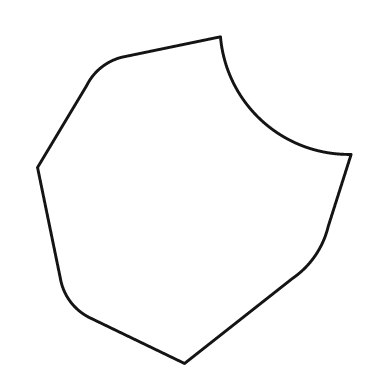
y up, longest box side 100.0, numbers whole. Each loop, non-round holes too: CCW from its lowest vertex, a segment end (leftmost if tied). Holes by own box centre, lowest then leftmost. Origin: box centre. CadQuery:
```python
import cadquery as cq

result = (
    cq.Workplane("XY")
    .moveTo(-3.0, -50.0)
    .lineTo(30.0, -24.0)
    .threePointArc((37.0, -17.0), (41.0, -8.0))
    .lineTo(48.0, 14.0)
    .threePointArc((21.0, 24.0), (8.0, 50.0))
    .lineTo(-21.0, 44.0)
    .threePointArc((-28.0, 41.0), (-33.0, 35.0))
    .lineTo(-48.0, 10.0)
    .lineTo(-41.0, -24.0)
    .threePointArc((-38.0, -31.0), (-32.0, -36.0))
    .close()
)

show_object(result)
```